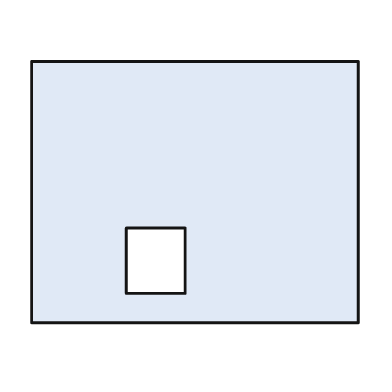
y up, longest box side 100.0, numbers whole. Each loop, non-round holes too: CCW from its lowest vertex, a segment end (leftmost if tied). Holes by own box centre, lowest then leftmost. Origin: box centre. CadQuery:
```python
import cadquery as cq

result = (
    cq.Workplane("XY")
    .moveTo(-50.0, -40.0)
    .lineTo(50.0, -40.0)
    .lineTo(50.0, 40.0)
    .lineTo(-50.0, 40.0)
    .close()
    .moveTo(-21.0, -31.0)
    .lineTo(-3.0, -31.0)
    .lineTo(-3.0, -11.0)
    .lineTo(-21.0, -11.0)
    .close()
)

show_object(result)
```